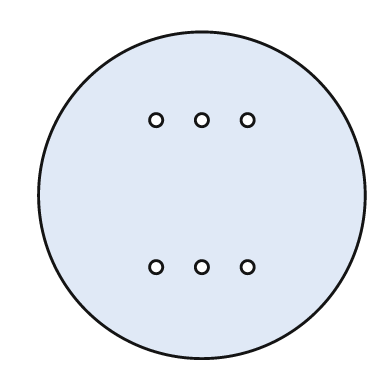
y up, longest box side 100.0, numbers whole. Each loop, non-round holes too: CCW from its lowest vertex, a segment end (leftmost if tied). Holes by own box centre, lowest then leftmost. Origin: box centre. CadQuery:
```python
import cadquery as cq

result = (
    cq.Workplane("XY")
    .moveTo(0.0, 0.0)
    .circle(50.0)
    .moveTo(-14.0, -22.0)
    .circle(2.0)
    .moveTo(0.0, -22.0)
    .circle(2.0)
    .moveTo(14.0, -22.0)
    .circle(2.0)
    .moveTo(-14.0, 23.0)
    .circle(2.0)
    .moveTo(0.0, 23.0)
    .circle(2.0)
    .moveTo(14.0, 23.0)
    .circle(2.0)
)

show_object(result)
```